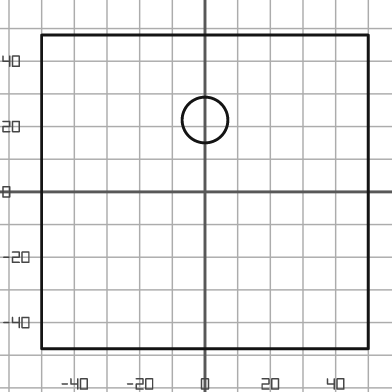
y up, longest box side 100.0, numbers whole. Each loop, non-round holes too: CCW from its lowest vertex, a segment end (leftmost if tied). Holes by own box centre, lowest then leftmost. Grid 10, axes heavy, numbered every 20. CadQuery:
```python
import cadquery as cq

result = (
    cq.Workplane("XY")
    .moveTo(-50.0, -48.0)
    .lineTo(50.0, -48.0)
    .lineTo(50.0, 48.0)
    .lineTo(-50.0, 48.0)
    .close()
    .moveTo(0.0, 22.0)
    .circle(7.0)
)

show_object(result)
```